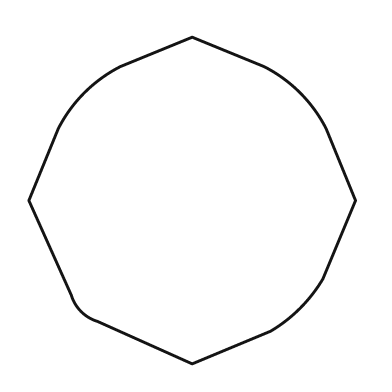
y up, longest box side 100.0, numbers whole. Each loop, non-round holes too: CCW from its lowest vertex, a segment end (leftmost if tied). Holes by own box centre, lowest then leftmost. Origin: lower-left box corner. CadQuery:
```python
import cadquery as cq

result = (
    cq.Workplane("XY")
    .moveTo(50.0, 0.0)
    .lineTo(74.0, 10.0)
    .threePointArc((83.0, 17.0), (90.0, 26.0))
    .lineTo(100.0, 50.0)
    .lineTo(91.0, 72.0)
    .threePointArc((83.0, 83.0), (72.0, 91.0))
    .lineTo(50.0, 100.0)
    .lineTo(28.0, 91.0)
    .threePointArc((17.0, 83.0), (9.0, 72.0))
    .lineTo(0.0, 50.0)
    .lineTo(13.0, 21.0)
    .threePointArc((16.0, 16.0), (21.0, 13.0))
    .close()
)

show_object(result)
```